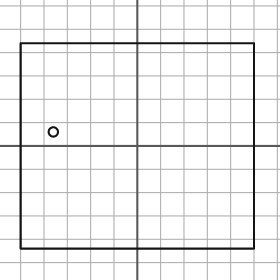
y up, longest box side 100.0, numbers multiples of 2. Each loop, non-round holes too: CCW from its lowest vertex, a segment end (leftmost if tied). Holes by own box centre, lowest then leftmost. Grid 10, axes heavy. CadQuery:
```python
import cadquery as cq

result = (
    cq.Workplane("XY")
    .moveTo(-50.0, -44.0)
    .lineTo(50.0, -44.0)
    .lineTo(50.0, 44.0)
    .lineTo(-50.0, 44.0)
    .close()
    .moveTo(-36.0, 6.0)
    .circle(2.0)
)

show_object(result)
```